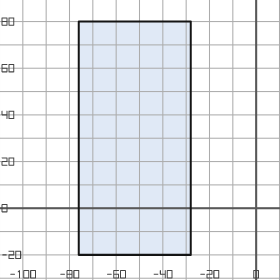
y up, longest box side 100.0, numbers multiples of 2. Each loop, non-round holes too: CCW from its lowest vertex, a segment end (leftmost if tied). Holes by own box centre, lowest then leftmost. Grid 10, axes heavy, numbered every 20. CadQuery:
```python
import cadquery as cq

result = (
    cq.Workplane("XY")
    .moveTo(-76.0, -20.0)
    .lineTo(-28.0, -20.0)
    .lineTo(-28.0, 80.0)
    .lineTo(-76.0, 80.0)
    .close()
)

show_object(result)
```